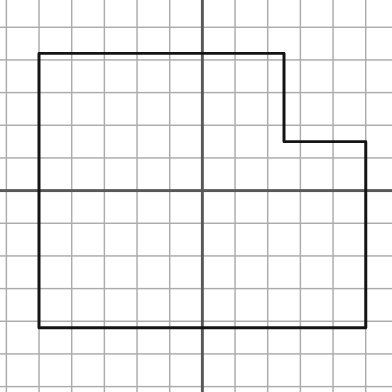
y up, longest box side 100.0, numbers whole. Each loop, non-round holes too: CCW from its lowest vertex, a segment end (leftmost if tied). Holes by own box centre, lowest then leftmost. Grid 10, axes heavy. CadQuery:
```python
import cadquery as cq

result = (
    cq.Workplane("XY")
    .moveTo(-50.0, -42.0)
    .lineTo(50.0, -42.0)
    .lineTo(50.0, 15.0)
    .lineTo(25.0, 15.0)
    .lineTo(25.0, 42.0)
    .lineTo(-50.0, 42.0)
    .close()
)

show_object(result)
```